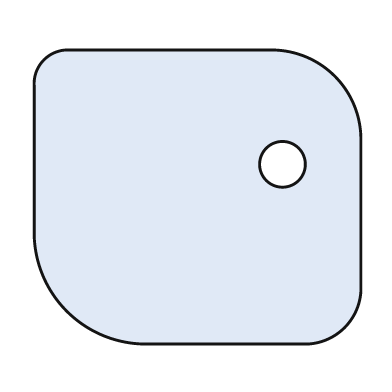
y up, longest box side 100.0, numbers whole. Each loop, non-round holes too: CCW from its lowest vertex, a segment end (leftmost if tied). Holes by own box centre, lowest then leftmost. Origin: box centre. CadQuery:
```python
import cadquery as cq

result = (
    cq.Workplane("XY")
    .moveTo(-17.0, -45.0)
    .lineTo(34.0, -45.0)
    .threePointArc((45.0, -40.0), (50.0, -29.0))
    .lineTo(50.0, 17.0)
    .threePointArc((42.0, 37.0), (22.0, 45.0))
    .lineTo(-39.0, 45.0)
    .threePointArc((-47.0, 42.0), (-50.0, 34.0))
    .lineTo(-50.0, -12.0)
    .threePointArc((-40.0, -35.0), (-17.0, -45.0))
    .close()
    .moveTo(26.0, 10.0)
    .circle(7.0)
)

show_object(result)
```